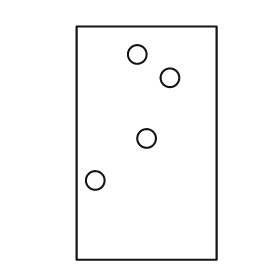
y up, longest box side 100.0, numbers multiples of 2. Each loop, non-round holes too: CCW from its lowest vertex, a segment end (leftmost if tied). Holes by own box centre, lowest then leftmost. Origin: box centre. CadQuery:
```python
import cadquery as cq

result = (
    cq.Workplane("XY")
    .moveTo(-30.0, -50.0)
    .lineTo(30.0, -50.0)
    .lineTo(30.0, 50.0)
    .lineTo(-30.0, 50.0)
    .close()
    .moveTo(-22.0, -16.0)
    .circle(4.0)
    .moveTo(0.0, 2.0)
    .circle(4.0)
    .moveTo(10.0, 28.0)
    .circle(4.0)
    .moveTo(-4.0, 38.0)
    .circle(4.0)
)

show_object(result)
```